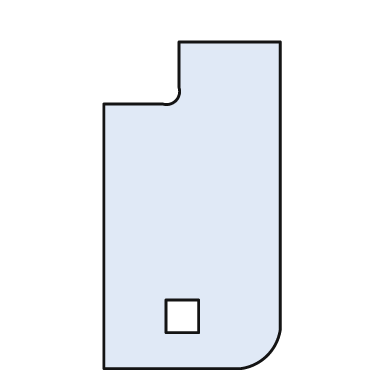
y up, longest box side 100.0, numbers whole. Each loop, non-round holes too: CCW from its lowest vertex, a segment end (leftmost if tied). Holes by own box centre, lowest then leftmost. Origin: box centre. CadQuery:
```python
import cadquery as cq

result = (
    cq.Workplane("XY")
    .moveTo(-27.0, -50.0)
    .lineTo(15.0, -50.0)
    .threePointArc((23.0, -46.0), (27.0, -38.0))
    .lineTo(27.0, 50.0)
    .lineTo(-4.0, 50.0)
    .lineTo(-4.0, 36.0)
    .threePointArc((-5.0, 32.0), (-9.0, 31.0))
    .lineTo(-27.0, 31.0)
    .close()
    .moveTo(-8.0, -39.0)
    .lineTo(2.0, -39.0)
    .lineTo(2.0, -29.0)
    .lineTo(-8.0, -29.0)
    .close()
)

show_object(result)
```